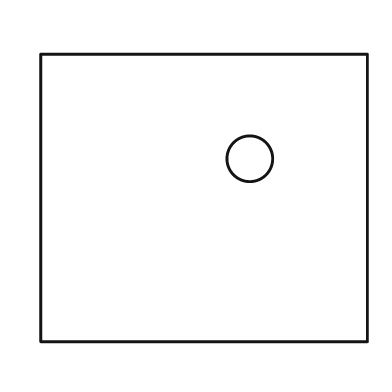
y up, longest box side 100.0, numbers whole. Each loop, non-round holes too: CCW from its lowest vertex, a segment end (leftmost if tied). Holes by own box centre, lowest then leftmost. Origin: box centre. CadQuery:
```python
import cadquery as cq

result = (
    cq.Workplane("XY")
    .moveTo(-50.0, -44.0)
    .lineTo(50.0, -44.0)
    .lineTo(50.0, 44.0)
    .lineTo(-50.0, 44.0)
    .close()
    .moveTo(14.0, 12.0)
    .circle(7.0)
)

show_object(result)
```